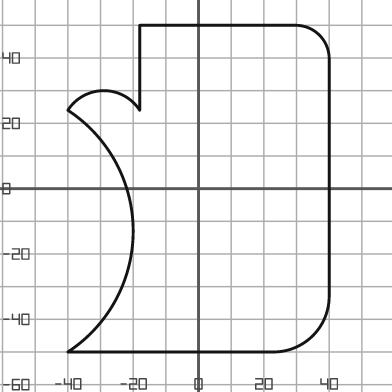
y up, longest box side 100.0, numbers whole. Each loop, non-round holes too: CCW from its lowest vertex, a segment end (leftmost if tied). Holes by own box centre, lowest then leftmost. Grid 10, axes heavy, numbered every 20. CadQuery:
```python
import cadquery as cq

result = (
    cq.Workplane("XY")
    .moveTo(-40.0, -50.0)
    .lineTo(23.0, -50.0)
    .threePointArc((35.0, -45.0), (40.0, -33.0))
    .lineTo(40.0, 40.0)
    .threePointArc((37.0, 47.0), (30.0, 50.0))
    .lineTo(-18.0, 50.0)
    .lineTo(-18.0, 24.0)
    .threePointArc((-29.0, 30.0), (-40.0, 24.0))
    .threePointArc((-20.0, -13.0), (-40.0, -50.0))
    .close()
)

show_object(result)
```